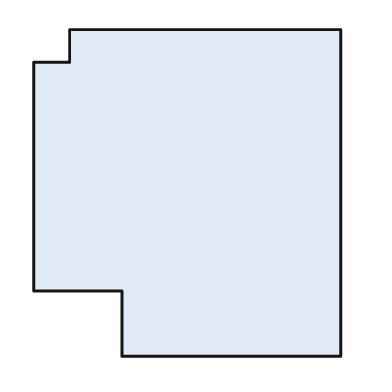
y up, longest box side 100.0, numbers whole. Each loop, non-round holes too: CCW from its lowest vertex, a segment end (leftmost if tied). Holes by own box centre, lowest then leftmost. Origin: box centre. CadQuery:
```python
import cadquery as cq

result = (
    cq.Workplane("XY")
    .moveTo(-20.0, -50.0)
    .lineTo(47.0, -50.0)
    .lineTo(47.0, 50.0)
    .lineTo(-36.0, 50.0)
    .lineTo(-36.0, 40.0)
    .lineTo(-47.0, 40.0)
    .lineTo(-47.0, -30.0)
    .lineTo(-20.0, -30.0)
    .close()
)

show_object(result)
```